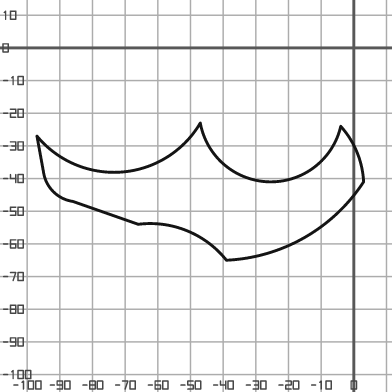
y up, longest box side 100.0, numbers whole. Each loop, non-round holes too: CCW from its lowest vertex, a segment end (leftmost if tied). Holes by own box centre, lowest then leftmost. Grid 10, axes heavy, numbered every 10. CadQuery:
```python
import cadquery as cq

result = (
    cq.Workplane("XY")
    .moveTo(-39.0, -65.0)
    .threePointArc((-15.0, -58.0), (3.0, -41.0))
    .threePointArc((1.0, -32.0), (-4.0, -24.0))
    .threePointArc((-26.0, -41.0), (-47.0, -23.0))
    .threePointArc((-71.0, -38.0), (-97.0, -27.0))
    .lineTo(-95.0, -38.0)
    .threePointArc((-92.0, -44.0), (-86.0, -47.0))
    .lineTo(-66.0, -54.0)
    .threePointArc((-51.0, -56.0), (-39.0, -65.0))
    .close()
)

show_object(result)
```